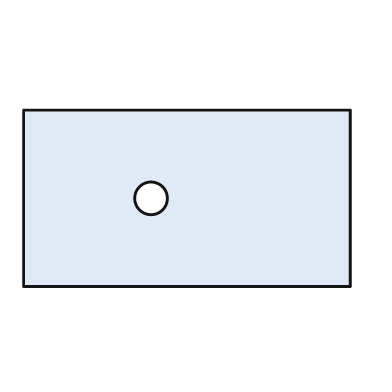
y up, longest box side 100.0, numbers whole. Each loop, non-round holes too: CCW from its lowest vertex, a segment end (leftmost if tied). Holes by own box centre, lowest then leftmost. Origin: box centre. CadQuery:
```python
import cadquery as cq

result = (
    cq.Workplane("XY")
    .moveTo(-50.0, -27.0)
    .lineTo(50.0, -27.0)
    .lineTo(50.0, 27.0)
    .lineTo(-50.0, 27.0)
    .close()
    .moveTo(-11.0, 0.0)
    .circle(5.0)
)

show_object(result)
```